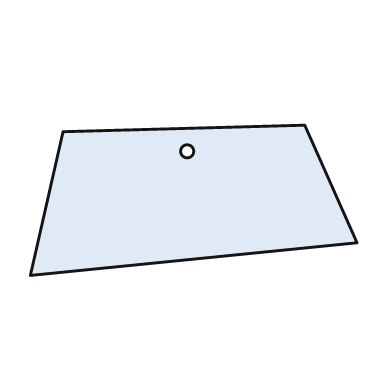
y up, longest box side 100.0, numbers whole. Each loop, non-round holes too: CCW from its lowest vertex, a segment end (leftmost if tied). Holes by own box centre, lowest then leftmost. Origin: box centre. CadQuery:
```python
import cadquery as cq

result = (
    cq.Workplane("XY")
    .moveTo(-50.0, -23.0)
    .lineTo(50.0, -13.0)
    .lineTo(34.0, 23.0)
    .lineTo(-40.0, 21.0)
    .close()
    .moveTo(-2.0, 15.0)
    .circle(2.0)
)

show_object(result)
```